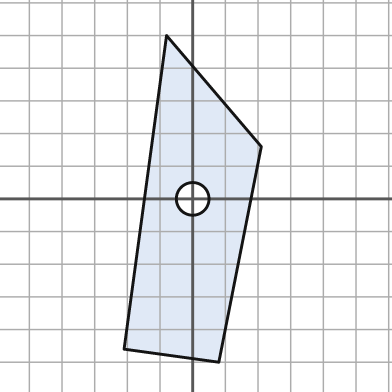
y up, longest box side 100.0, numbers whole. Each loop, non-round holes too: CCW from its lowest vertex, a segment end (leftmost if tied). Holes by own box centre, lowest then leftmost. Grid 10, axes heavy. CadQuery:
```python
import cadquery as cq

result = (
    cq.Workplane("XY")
    .moveTo(8.0, -50.0)
    .lineTo(21.0, 16.0)
    .lineTo(-8.0, 50.0)
    .lineTo(-21.0, -46.0)
    .close()
    .moveTo(0.0, 0.0)
    .circle(5.0)
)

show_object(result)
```